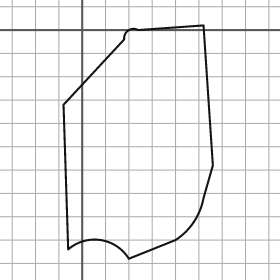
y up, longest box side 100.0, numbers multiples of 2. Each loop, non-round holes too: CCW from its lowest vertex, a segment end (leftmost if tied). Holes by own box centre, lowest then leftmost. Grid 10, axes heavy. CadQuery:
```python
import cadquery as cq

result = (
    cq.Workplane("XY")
    .moveTo(20.0, -98.0)
    .lineTo(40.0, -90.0)
    .threePointArc((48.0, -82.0), (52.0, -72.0))
    .lineTo(56.0, -58.0)
    .lineTo(52.0, 2.0)
    .lineTo(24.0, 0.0)
    .threePointArc((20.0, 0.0), (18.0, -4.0))
    .lineTo(-8.0, -32.0)
    .lineTo(-6.0, -94.0)
    .threePointArc((8.0, -90.0), (20.0, -98.0))
    .close()
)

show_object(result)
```